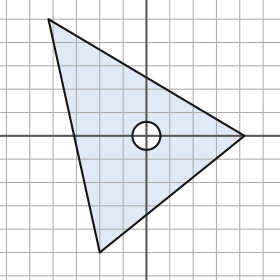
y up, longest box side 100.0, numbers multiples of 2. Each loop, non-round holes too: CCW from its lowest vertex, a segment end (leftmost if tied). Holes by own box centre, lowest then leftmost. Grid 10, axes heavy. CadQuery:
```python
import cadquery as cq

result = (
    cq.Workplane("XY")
    .moveTo(-20.0, -50.0)
    .lineTo(42.0, 0.0)
    .lineTo(-42.0, 50.0)
    .close()
    .moveTo(0.0, 0.0)
    .circle(6.0)
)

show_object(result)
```